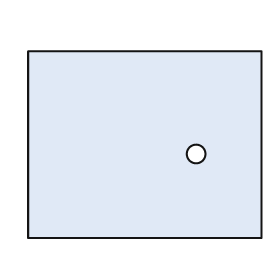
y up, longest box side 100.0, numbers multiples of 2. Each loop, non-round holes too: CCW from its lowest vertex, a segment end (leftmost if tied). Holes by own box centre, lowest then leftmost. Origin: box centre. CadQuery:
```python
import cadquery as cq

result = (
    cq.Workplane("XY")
    .moveTo(-50.0, -40.0)
    .lineTo(50.0, -40.0)
    .lineTo(50.0, 40.0)
    .lineTo(-50.0, 40.0)
    .close()
    .moveTo(22.0, -4.0)
    .circle(4.0)
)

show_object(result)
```